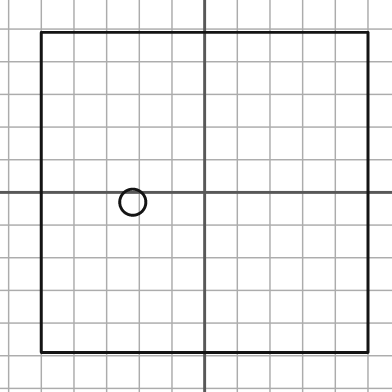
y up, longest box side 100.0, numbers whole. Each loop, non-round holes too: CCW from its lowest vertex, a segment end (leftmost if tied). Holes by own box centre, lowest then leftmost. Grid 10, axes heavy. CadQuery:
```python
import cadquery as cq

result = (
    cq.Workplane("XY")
    .moveTo(-50.0, -49.0)
    .lineTo(50.0, -49.0)
    .lineTo(50.0, 49.0)
    .lineTo(-50.0, 49.0)
    .close()
    .moveTo(-22.0, -3.0)
    .circle(4.0)
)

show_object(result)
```